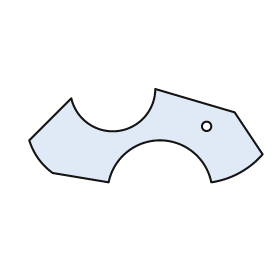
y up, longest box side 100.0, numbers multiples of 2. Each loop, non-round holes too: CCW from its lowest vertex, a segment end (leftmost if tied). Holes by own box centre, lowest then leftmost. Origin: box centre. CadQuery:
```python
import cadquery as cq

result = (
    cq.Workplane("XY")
    .moveTo(-16.0, -20.0)
    .threePointArc((6.0, -2.0), (28.0, -20.0))
    .threePointArc((40.0, -16.0), (50.0, -8.0))
    .lineTo(38.0, 10.0)
    .lineTo(4.0, 20.0)
    .threePointArc((-12.0, 2.0), (-32.0, 16.0))
    .lineTo(-50.0, -2.0)
    .threePointArc((-46.0, -10.0), (-40.0, -16.0))
    .close()
    .moveTo(26.0, 4.0)
    .circle(2.0)
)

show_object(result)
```